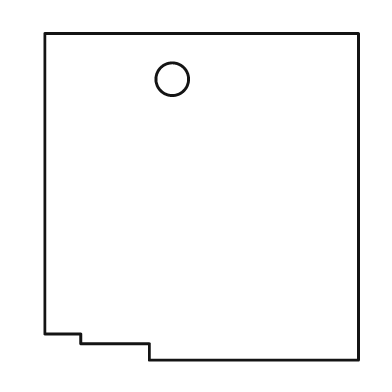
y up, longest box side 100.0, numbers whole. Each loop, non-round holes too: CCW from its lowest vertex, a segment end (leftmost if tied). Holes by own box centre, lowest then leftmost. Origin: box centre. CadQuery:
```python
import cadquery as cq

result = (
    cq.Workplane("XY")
    .moveTo(-16.0, -50.0)
    .lineTo(48.0, -50.0)
    .lineTo(48.0, 50.0)
    .lineTo(-48.0, 50.0)
    .lineTo(-48.0, -42.0)
    .lineTo(-37.0, -42.0)
    .lineTo(-37.0, -45.0)
    .lineTo(-16.0, -45.0)
    .close()
    .moveTo(-9.0, 36.0)
    .circle(5.0)
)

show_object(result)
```